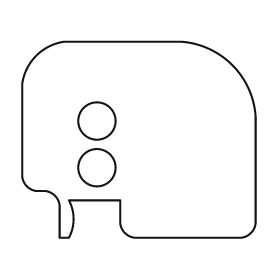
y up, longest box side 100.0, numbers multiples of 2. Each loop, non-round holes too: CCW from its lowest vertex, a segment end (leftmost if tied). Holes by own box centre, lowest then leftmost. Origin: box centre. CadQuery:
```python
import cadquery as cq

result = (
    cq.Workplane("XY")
    .moveTo(-34.0, -42.0)
    .lineTo(-30.0, -42.0)
    .threePointArc((-28.0, -34.0), (-30.0, -26.0))
    .lineTo(-8.0, -26.0)
    .lineTo(-8.0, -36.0)
    .threePointArc((-6.0, -40.0), (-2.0, -42.0))
    .lineTo(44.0, -42.0)
    .threePointArc((48.0, -40.0), (50.0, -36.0))
    .lineTo(50.0, 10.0)
    .threePointArc((40.0, 32.0), (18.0, 42.0))
    .lineTo(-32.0, 42.0)
    .threePointArc((-44.0, 36.0), (-50.0, 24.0))
    .lineTo(-50.0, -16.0)
    .threePointArc((-48.0, -20.0), (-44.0, -22.0))
    .lineTo(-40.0, -22.0)
    .threePointArc((-36.0, -24.0), (-34.0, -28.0))
    .close()
    .moveTo(-18.0, -12.0)
    .circle(8.0)
    .moveTo(-18.0, 8.0)
    .circle(8.0)
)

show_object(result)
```